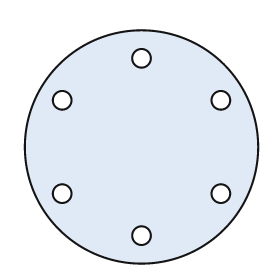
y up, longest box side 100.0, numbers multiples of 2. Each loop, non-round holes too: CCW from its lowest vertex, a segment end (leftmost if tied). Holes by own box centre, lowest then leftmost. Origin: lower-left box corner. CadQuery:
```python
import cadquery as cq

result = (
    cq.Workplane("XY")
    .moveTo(50.0, 50.0)
    .circle(50.0)
    .moveTo(50.0, 12.0)
    .circle(4.0)
    .moveTo(16.0, 30.0)
    .circle(4.0)
    .moveTo(84.0, 30.0)
    .circle(4.0)
    .moveTo(16.0, 70.0)
    .circle(4.0)
    .moveTo(84.0, 70.0)
    .circle(4.0)
    .moveTo(50.0, 88.0)
    .circle(4.0)
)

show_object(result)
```